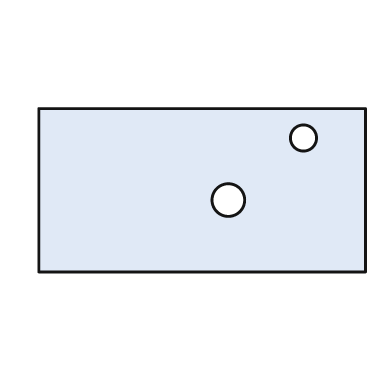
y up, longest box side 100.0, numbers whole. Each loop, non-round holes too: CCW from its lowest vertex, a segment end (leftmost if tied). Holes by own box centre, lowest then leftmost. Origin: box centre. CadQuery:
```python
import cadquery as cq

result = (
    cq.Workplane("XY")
    .moveTo(-50.0, -25.0)
    .lineTo(50.0, -25.0)
    .lineTo(50.0, 25.0)
    .lineTo(-50.0, 25.0)
    .close()
    .moveTo(8.0, -3.0)
    .circle(5.0)
    .moveTo(31.0, 16.0)
    .circle(4.0)
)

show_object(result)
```